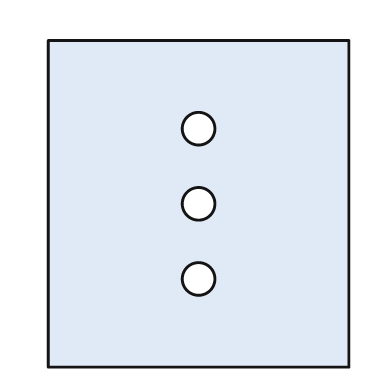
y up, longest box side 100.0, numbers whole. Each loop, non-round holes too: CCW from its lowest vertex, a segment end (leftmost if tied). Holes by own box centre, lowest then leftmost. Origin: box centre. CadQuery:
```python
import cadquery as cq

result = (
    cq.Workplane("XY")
    .moveTo(-46.0, -50.0)
    .lineTo(46.0, -50.0)
    .lineTo(46.0, 50.0)
    .lineTo(-46.0, 50.0)
    .close()
    .moveTo(0.0, -23.0)
    .circle(5.0)
    .moveTo(0.0, 0.0)
    .circle(5.0)
    .moveTo(0.0, 23.0)
    .circle(5.0)
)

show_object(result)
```